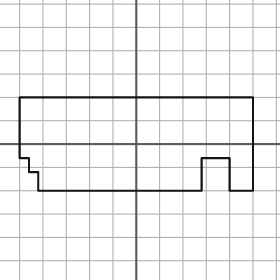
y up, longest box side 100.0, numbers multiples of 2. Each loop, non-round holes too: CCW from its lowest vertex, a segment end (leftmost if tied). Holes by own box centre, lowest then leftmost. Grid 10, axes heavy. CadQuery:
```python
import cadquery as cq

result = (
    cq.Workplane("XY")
    .moveTo(-42.0, -20.0)
    .lineTo(28.0, -20.0)
    .lineTo(28.0, -6.0)
    .lineTo(40.0, -6.0)
    .lineTo(40.0, -20.0)
    .lineTo(50.0, -20.0)
    .lineTo(50.0, 20.0)
    .lineTo(-50.0, 20.0)
    .lineTo(-50.0, -6.0)
    .lineTo(-46.0, -6.0)
    .lineTo(-46.0, -12.0)
    .lineTo(-42.0, -12.0)
    .close()
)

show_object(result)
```